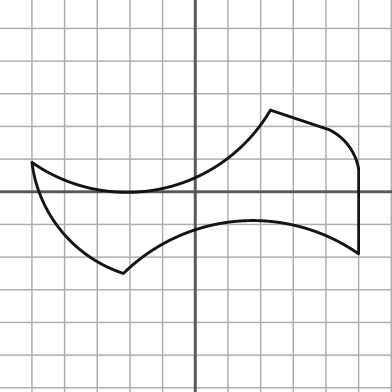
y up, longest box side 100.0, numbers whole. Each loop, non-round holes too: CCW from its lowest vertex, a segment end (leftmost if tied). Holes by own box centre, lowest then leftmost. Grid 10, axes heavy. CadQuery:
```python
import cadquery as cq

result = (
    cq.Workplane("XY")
    .moveTo(-22.0, -25.0)
    .threePointArc((13.0, -9.0), (50.0, -19.0))
    .lineTo(50.0, 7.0)
    .threePointArc((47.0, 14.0), (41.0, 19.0))
    .lineTo(23.0, 25.0)
    .threePointArc((-10.0, 1.0), (-50.0, 9.0))
    .threePointArc((-41.0, -12.0), (-22.0, -25.0))
    .close()
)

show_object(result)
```